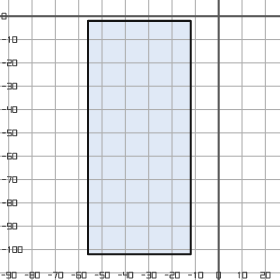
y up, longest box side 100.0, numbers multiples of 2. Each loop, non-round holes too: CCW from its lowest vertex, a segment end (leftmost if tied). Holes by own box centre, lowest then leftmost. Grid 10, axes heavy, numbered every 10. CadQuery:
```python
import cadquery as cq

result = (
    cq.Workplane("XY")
    .moveTo(-56.0, -102.0)
    .lineTo(-12.0, -102.0)
    .lineTo(-12.0, -2.0)
    .lineTo(-56.0, -2.0)
    .close()
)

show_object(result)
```